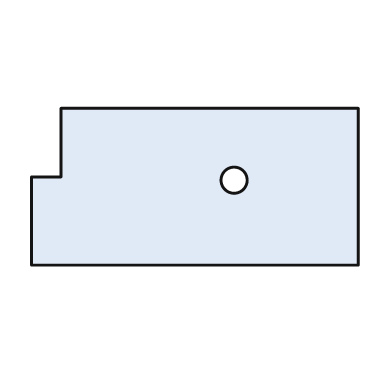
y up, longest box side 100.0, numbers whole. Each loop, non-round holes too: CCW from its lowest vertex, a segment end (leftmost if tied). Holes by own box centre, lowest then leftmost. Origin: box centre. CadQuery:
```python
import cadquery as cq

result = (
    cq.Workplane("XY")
    .moveTo(-50.0, -24.0)
    .lineTo(50.0, -24.0)
    .lineTo(50.0, 24.0)
    .lineTo(-41.0, 24.0)
    .lineTo(-41.0, 3.0)
    .lineTo(-50.0, 3.0)
    .close()
    .moveTo(12.0, 2.0)
    .circle(4.0)
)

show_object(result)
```